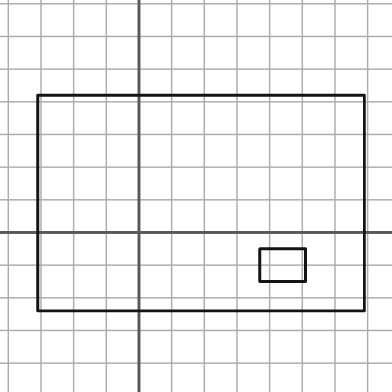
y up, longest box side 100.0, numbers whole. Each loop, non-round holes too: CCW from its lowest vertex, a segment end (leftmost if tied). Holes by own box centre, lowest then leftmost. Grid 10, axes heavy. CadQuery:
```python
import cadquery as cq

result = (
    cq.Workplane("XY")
    .moveTo(-31.0, -24.0)
    .lineTo(69.0, -24.0)
    .lineTo(69.0, 42.0)
    .lineTo(-31.0, 42.0)
    .close()
    .moveTo(37.0, -15.0)
    .lineTo(51.0, -15.0)
    .lineTo(51.0, -5.0)
    .lineTo(37.0, -5.0)
    .close()
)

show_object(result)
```